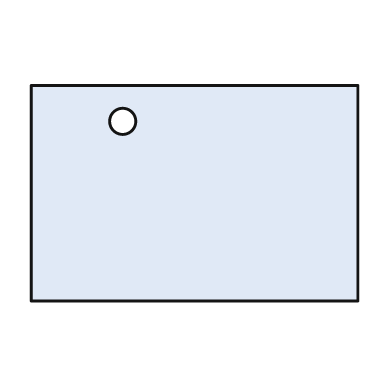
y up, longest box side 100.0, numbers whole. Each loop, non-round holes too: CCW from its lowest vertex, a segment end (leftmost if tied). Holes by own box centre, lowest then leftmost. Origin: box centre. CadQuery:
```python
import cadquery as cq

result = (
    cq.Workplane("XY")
    .moveTo(-50.0, -33.0)
    .lineTo(50.0, -33.0)
    .lineTo(50.0, 33.0)
    .lineTo(-50.0, 33.0)
    .close()
    .moveTo(-22.0, 22.0)
    .circle(4.0)
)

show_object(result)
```